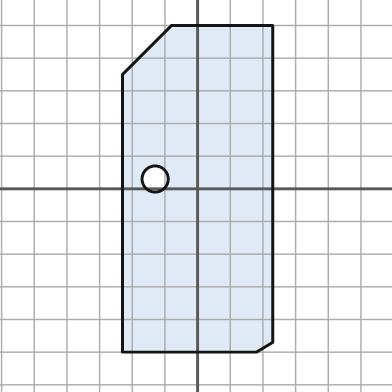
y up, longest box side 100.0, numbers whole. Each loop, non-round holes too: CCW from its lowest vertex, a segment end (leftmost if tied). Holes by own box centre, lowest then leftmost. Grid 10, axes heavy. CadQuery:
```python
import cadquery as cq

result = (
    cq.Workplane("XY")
    .moveTo(-23.0, -50.0)
    .lineTo(18.0, -50.0)
    .lineTo(23.0, -47.0)
    .lineTo(23.0, 50.0)
    .lineTo(-8.0, 50.0)
    .lineTo(-23.0, 35.0)
    .close()
    .moveTo(-13.0, 3.0)
    .circle(4.0)
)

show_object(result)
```